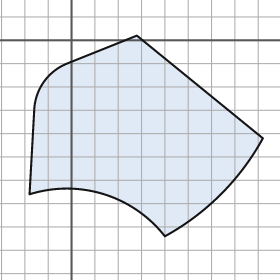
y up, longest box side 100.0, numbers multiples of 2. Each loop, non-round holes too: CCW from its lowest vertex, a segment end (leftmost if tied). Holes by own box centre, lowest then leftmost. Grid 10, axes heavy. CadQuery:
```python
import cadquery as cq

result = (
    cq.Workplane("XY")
    .moveTo(40.0, -84.0)
    .threePointArc((64.0, -66.0), (82.0, -42.0))
    .lineTo(28.0, 2.0)
    .lineTo(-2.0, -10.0)
    .threePointArc((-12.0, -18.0), (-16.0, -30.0))
    .lineTo(-18.0, -66.0)
    .threePointArc((14.0, -66.0), (40.0, -84.0))
    .close()
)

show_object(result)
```